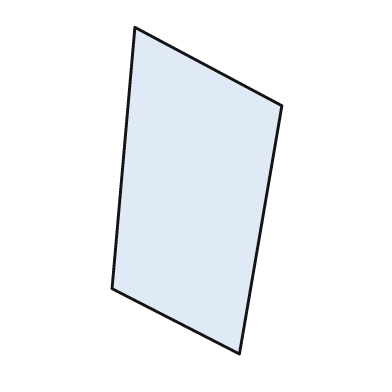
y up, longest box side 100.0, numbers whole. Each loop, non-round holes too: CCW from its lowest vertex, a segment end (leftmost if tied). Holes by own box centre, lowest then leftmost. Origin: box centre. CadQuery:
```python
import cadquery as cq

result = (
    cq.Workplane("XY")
    .moveTo(13.0, -50.0)
    .lineTo(26.0, 26.0)
    .lineTo(-19.0, 50.0)
    .lineTo(-26.0, -30.0)
    .close()
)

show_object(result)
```